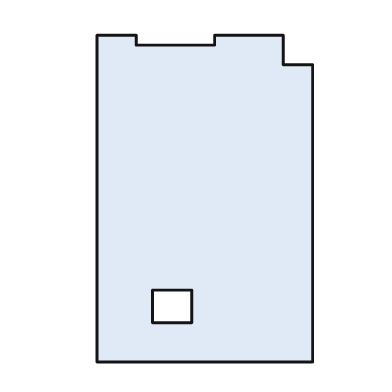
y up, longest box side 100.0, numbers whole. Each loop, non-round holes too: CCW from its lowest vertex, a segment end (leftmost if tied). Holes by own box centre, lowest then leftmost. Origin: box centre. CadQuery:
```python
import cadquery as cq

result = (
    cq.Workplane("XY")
    .moveTo(-33.0, -50.0)
    .lineTo(33.0, -50.0)
    .lineTo(33.0, 41.0)
    .lineTo(24.0, 41.0)
    .lineTo(24.0, 50.0)
    .lineTo(3.0, 50.0)
    .lineTo(3.0, 47.0)
    .lineTo(-21.0, 47.0)
    .lineTo(-21.0, 50.0)
    .lineTo(-33.0, 50.0)
    .close()
    .moveTo(-16.0, -38.0)
    .lineTo(-4.0, -38.0)
    .lineTo(-4.0, -28.0)
    .lineTo(-16.0, -28.0)
    .close()
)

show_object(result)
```